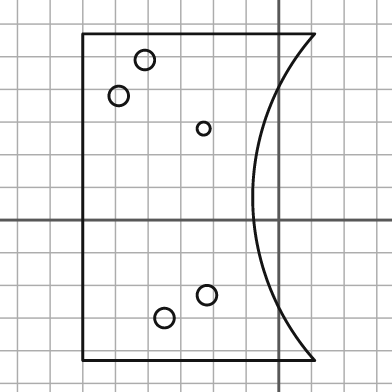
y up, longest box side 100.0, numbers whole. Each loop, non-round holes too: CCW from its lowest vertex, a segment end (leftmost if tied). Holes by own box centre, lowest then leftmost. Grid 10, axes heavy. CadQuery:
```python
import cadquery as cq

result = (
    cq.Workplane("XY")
    .moveTo(-60.0, -43.0)
    .lineTo(11.0, -43.0)
    .threePointArc((-8.0, 7.0), (11.0, 57.0))
    .lineTo(-60.0, 57.0)
    .close()
    .moveTo(-35.0, -30.0)
    .circle(3.0)
    .moveTo(-22.0, -23.0)
    .circle(3.0)
    .moveTo(-23.0, 28.0)
    .circle(2.0)
    .moveTo(-49.0, 38.0)
    .circle(3.0)
    .moveTo(-41.0, 49.0)
    .circle(3.0)
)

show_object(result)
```